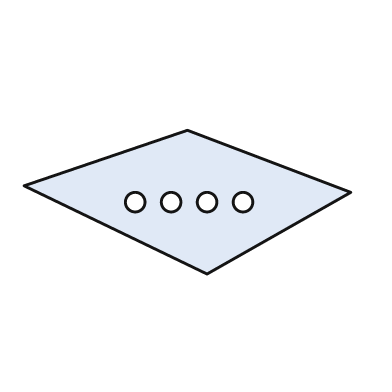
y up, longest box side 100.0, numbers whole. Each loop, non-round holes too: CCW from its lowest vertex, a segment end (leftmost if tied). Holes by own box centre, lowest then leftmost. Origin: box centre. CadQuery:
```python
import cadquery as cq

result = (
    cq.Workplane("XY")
    .moveTo(6.0, -22.0)
    .lineTo(50.0, 3.0)
    .lineTo(0.0, 22.0)
    .lineTo(-50.0, 5.0)
    .close()
    .moveTo(-16.0, 0.0)
    .circle(3.0)
    .moveTo(-5.0, 0.0)
    .circle(3.0)
    .moveTo(6.0, 0.0)
    .circle(3.0)
    .moveTo(17.0, 0.0)
    .circle(3.0)
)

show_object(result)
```